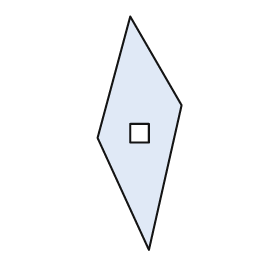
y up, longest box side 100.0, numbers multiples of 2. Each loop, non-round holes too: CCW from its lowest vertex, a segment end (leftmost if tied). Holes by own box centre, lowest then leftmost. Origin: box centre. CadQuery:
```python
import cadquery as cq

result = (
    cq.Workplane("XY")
    .moveTo(4.0, -50.0)
    .lineTo(18.0, 12.0)
    .lineTo(-4.0, 50.0)
    .lineTo(-18.0, -2.0)
    .close()
    .moveTo(-4.0, -4.0)
    .lineTo(4.0, -4.0)
    .lineTo(4.0, 4.0)
    .lineTo(-4.0, 4.0)
    .close()
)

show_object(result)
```